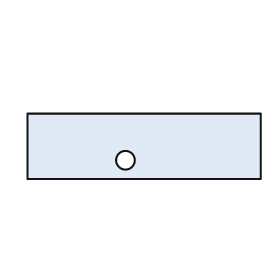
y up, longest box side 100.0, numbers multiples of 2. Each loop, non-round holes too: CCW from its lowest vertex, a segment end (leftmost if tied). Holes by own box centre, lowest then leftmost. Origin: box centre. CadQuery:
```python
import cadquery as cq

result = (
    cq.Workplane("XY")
    .moveTo(-50.0, -14.0)
    .lineTo(50.0, -14.0)
    .lineTo(50.0, 14.0)
    .lineTo(-50.0, 14.0)
    .close()
    .moveTo(-8.0, -6.0)
    .circle(4.0)
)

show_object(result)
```